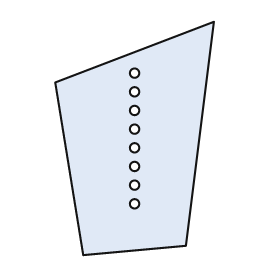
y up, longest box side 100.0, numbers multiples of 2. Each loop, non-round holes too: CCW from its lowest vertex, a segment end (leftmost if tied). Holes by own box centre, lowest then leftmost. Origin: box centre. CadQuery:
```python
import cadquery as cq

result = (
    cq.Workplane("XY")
    .moveTo(-22.0, -50.0)
    .lineTo(22.0, -46.0)
    .lineTo(34.0, 50.0)
    .lineTo(-34.0, 24.0)
    .close()
    .moveTo(0.0, -28.0)
    .circle(2.0)
    .moveTo(0.0, -20.0)
    .circle(2.0)
    .moveTo(0.0, -12.0)
    .circle(2.0)
    .moveTo(0.0, -4.0)
    .circle(2.0)
    .moveTo(0.0, 4.0)
    .circle(2.0)
    .moveTo(0.0, 12.0)
    .circle(2.0)
    .moveTo(0.0, 20.0)
    .circle(2.0)
    .moveTo(0.0, 28.0)
    .circle(2.0)
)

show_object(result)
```